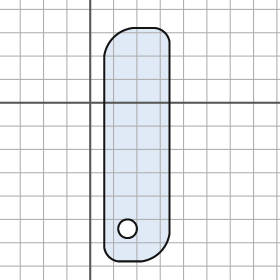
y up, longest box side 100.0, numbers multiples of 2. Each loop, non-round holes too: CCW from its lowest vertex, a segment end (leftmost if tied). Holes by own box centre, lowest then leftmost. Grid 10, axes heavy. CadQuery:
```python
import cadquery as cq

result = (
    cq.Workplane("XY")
    .moveTo(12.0, -68.0)
    .lineTo(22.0, -68.0)
    .threePointArc((30.0, -64.0), (34.0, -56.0))
    .lineTo(34.0, 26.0)
    .threePointArc((32.0, 30.0), (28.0, 32.0))
    .lineTo(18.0, 32.0)
    .threePointArc((10.0, 28.0), (6.0, 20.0))
    .lineTo(6.0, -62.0)
    .threePointArc((8.0, -66.0), (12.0, -68.0))
    .close()
    .moveTo(16.0, -54.0)
    .circle(4.0)
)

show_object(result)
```